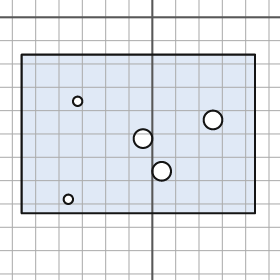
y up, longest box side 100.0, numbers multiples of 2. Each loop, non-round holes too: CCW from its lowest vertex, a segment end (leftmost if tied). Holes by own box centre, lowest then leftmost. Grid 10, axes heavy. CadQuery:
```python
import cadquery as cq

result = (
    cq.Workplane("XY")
    .moveTo(-56.0, -84.0)
    .lineTo(44.0, -84.0)
    .lineTo(44.0, -16.0)
    .lineTo(-56.0, -16.0)
    .close()
    .moveTo(-36.0, -78.0)
    .circle(2.0)
    .moveTo(4.0, -66.0)
    .circle(4.0)
    .moveTo(-4.0, -52.0)
    .circle(4.0)
    .moveTo(26.0, -44.0)
    .circle(4.0)
    .moveTo(-32.0, -36.0)
    .circle(2.0)
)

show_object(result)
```